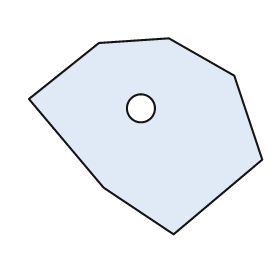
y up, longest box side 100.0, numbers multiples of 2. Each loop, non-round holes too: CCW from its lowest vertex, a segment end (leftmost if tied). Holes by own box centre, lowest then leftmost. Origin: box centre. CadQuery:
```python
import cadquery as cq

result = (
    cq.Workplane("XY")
    .moveTo(12.0, -42.0)
    .lineTo(50.0, -10.0)
    .lineTo(38.0, 26.0)
    .lineTo(10.0, 42.0)
    .lineTo(-20.0, 40.0)
    .lineTo(-50.0, 16.0)
    .lineTo(-18.0, -22.0)
    .close()
    .moveTo(-2.0, 12.0)
    .circle(6.0)
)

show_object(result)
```